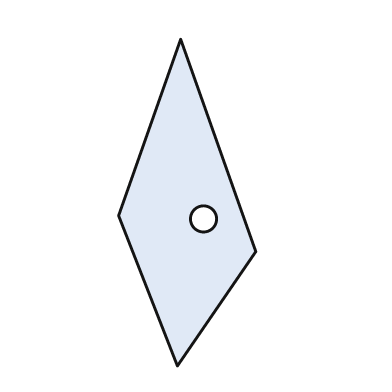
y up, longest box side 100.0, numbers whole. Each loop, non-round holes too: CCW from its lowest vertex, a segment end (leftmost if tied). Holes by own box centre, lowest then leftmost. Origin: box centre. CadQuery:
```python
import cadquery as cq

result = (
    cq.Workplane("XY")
    .moveTo(-3.0, -50.0)
    .lineTo(21.0, -15.0)
    .lineTo(-2.0, 50.0)
    .lineTo(-21.0, -4.0)
    .close()
    .moveTo(5.0, -5.0)
    .circle(4.0)
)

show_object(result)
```